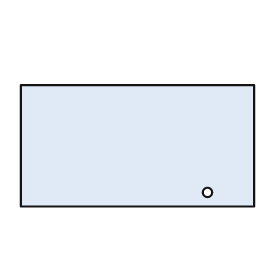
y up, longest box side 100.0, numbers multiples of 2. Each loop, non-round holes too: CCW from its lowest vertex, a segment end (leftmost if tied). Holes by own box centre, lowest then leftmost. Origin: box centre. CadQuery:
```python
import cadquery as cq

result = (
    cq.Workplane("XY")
    .moveTo(-50.0, -26.0)
    .lineTo(50.0, -26.0)
    .lineTo(50.0, 26.0)
    .lineTo(-50.0, 26.0)
    .close()
    .moveTo(30.0, -20.0)
    .circle(2.0)
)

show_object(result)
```